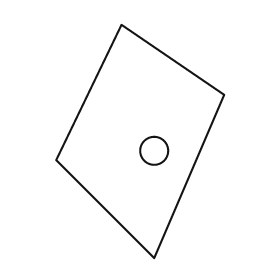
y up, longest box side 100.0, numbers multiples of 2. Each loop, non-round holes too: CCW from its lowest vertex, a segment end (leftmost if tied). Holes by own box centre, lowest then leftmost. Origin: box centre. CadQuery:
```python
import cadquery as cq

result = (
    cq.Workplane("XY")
    .moveTo(6.0, -50.0)
    .lineTo(36.0, 20.0)
    .lineTo(-8.0, 50.0)
    .lineTo(-36.0, -8.0)
    .close()
    .moveTo(6.0, -4.0)
    .circle(6.0)
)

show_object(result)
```